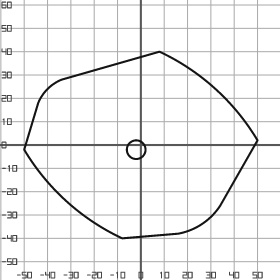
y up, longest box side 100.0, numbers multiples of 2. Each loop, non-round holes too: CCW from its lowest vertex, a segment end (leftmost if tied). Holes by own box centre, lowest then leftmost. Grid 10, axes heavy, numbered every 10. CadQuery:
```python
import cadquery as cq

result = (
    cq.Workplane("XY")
    .moveTo(-8.0, -40.0)
    .lineTo(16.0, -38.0)
    .threePointArc((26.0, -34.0), (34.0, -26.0))
    .lineTo(50.0, 2.0)
    .threePointArc((32.0, 24.0), (8.0, 40.0))
    .lineTo(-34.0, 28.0)
    .threePointArc((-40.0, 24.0), (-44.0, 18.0))
    .lineTo(-50.0, -2.0)
    .threePointArc((-32.0, -24.0), (-8.0, -40.0))
    .close()
    .moveTo(-2.0, -2.0)
    .circle(4.0)
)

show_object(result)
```